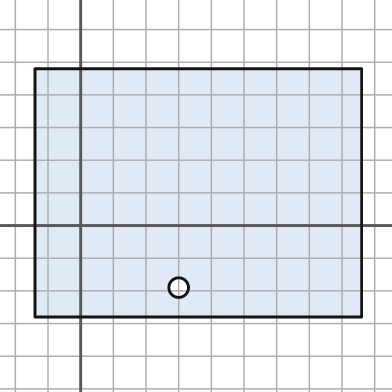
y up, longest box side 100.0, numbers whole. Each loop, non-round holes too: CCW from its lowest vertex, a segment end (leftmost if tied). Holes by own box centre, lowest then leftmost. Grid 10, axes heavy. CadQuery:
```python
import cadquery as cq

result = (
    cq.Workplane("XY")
    .moveTo(-14.0, -28.0)
    .lineTo(86.0, -28.0)
    .lineTo(86.0, 48.0)
    .lineTo(-14.0, 48.0)
    .close()
    .moveTo(30.0, -19.0)
    .circle(3.0)
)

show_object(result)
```